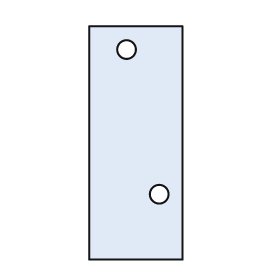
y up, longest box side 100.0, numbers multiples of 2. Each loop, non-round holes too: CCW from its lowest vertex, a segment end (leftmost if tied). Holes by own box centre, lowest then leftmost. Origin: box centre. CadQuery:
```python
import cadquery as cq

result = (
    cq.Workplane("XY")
    .moveTo(-20.0, -50.0)
    .lineTo(20.0, -50.0)
    .lineTo(20.0, 50.0)
    .lineTo(-20.0, 50.0)
    .close()
    .moveTo(10.0, -22.0)
    .circle(4.0)
    .moveTo(-4.0, 40.0)
    .circle(4.0)
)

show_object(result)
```